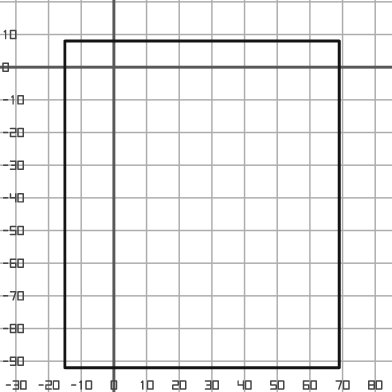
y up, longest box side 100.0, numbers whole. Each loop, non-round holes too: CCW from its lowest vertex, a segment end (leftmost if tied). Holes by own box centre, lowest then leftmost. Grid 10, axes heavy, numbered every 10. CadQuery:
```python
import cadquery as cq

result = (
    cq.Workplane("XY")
    .moveTo(-15.0, -92.0)
    .lineTo(69.0, -92.0)
    .lineTo(69.0, 8.0)
    .lineTo(-15.0, 8.0)
    .close()
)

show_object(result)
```